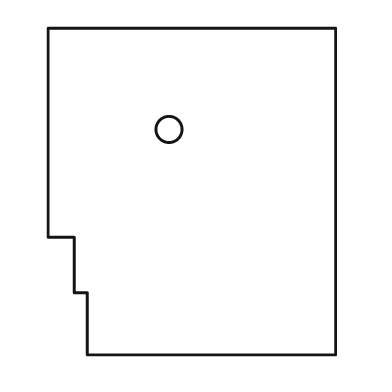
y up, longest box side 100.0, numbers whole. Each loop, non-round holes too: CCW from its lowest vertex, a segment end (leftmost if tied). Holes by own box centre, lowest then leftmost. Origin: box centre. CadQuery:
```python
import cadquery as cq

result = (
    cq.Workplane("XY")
    .moveTo(-32.0, -50.0)
    .lineTo(44.0, -50.0)
    .lineTo(44.0, 50.0)
    .lineTo(-44.0, 50.0)
    .lineTo(-44.0, -14.0)
    .lineTo(-36.0, -14.0)
    .lineTo(-36.0, -31.0)
    .lineTo(-32.0, -31.0)
    .close()
    .moveTo(-7.0, 19.0)
    .circle(4.0)
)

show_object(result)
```